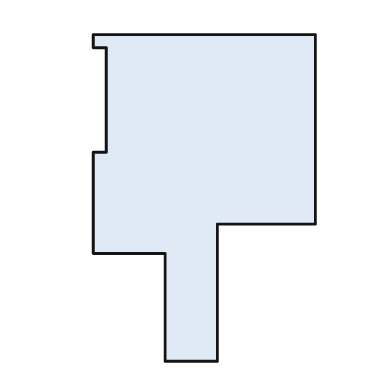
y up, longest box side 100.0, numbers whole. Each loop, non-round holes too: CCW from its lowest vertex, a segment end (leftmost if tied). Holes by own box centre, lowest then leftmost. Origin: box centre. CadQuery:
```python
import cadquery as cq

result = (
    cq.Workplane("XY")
    .moveTo(-12.0, -50.0)
    .lineTo(4.0, -50.0)
    .lineTo(4.0, -8.0)
    .lineTo(34.0, -8.0)
    .lineTo(34.0, 50.0)
    .lineTo(-34.0, 50.0)
    .lineTo(-34.0, 46.0)
    .lineTo(-30.0, 46.0)
    .lineTo(-30.0, 14.0)
    .lineTo(-34.0, 14.0)
    .lineTo(-34.0, -17.0)
    .lineTo(-12.0, -17.0)
    .close()
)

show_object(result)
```